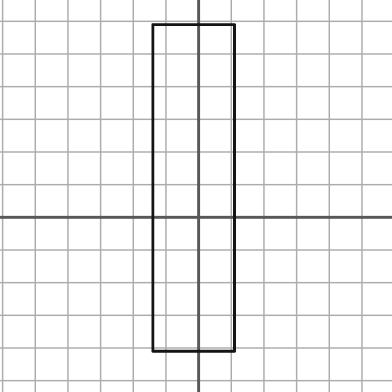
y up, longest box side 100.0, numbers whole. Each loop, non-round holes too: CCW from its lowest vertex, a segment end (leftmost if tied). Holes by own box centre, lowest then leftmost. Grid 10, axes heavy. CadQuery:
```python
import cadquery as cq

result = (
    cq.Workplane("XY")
    .moveTo(-14.0, -41.0)
    .lineTo(11.0, -41.0)
    .lineTo(11.0, 59.0)
    .lineTo(-14.0, 59.0)
    .close()
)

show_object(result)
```